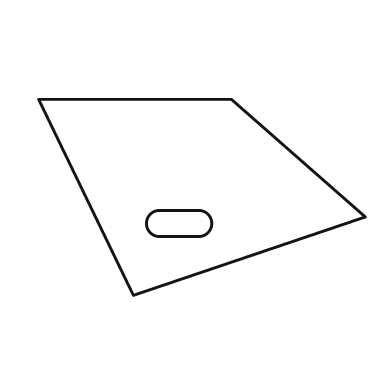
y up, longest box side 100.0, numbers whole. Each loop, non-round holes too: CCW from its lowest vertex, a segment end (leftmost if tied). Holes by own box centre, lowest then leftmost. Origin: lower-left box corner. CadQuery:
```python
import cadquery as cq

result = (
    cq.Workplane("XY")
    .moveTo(29.0, 0.0)
    .lineTo(100.0, 24.0)
    .lineTo(59.0, 60.0)
    .lineTo(0.0, 60.0)
    .close()
    .moveTo(37.0, 18.0)
    .lineTo(49.0, 18.0)
    .threePointArc((53.0, 22.0), (49.0, 26.0))
    .lineTo(37.0, 26.0)
    .threePointArc((33.0, 22.0), (37.0, 18.0))
    .close()
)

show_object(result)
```